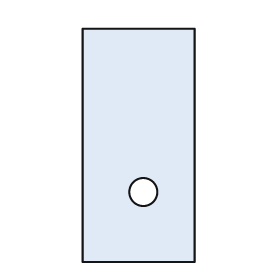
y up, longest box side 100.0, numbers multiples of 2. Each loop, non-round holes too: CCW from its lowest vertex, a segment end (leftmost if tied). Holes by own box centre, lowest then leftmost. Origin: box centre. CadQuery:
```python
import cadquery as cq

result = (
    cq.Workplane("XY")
    .moveTo(-24.0, -50.0)
    .lineTo(24.0, -50.0)
    .lineTo(24.0, 50.0)
    .lineTo(-24.0, 50.0)
    .close()
    .moveTo(2.0, -20.0)
    .circle(6.0)
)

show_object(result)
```